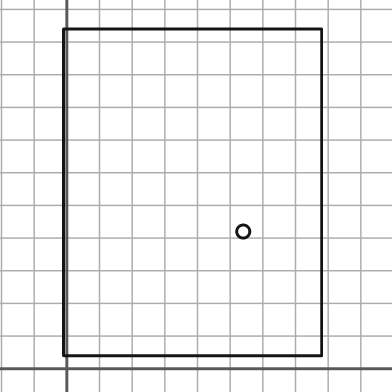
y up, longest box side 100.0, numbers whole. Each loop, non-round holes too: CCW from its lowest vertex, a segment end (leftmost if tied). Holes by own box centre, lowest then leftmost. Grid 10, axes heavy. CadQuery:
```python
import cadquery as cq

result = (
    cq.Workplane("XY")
    .moveTo(-1.0, 4.0)
    .lineTo(78.0, 4.0)
    .lineTo(78.0, 104.0)
    .lineTo(-1.0, 104.0)
    .close()
    .moveTo(54.0, 42.0)
    .circle(2.0)
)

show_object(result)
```